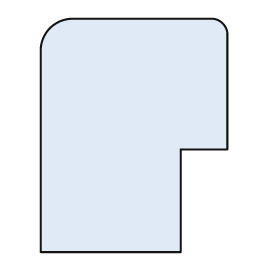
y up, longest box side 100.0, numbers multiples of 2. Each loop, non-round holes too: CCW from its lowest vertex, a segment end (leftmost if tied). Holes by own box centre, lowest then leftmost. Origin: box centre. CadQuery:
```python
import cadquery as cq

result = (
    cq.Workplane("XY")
    .moveTo(-40.0, -50.0)
    .lineTo(20.0, -50.0)
    .lineTo(20.0, -6.0)
    .lineTo(40.0, -6.0)
    .lineTo(40.0, 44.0)
    .threePointArc((38.0, 48.0), (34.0, 50.0))
    .lineTo(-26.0, 50.0)
    .threePointArc((-36.0, 46.0), (-40.0, 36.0))
    .close()
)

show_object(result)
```